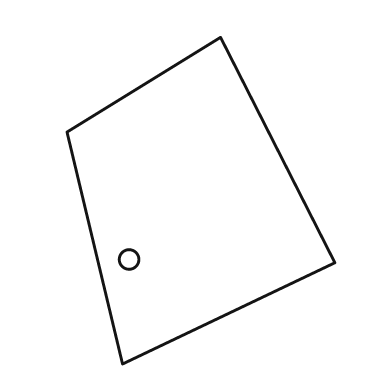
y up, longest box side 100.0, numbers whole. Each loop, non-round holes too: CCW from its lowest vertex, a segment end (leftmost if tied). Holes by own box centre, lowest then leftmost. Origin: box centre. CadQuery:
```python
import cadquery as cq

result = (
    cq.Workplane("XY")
    .moveTo(-24.0, -50.0)
    .lineTo(41.0, -19.0)
    .lineTo(6.0, 50.0)
    .lineTo(-41.0, 21.0)
    .close()
    .moveTo(-22.0, -18.0)
    .circle(3.0)
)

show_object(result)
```